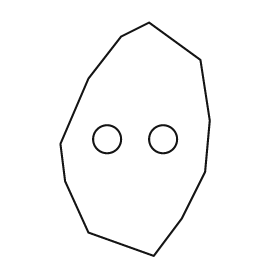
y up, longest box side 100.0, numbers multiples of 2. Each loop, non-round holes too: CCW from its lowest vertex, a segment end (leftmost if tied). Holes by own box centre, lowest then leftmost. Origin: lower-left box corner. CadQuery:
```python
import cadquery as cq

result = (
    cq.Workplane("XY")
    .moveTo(40.0, 0.0)
    .lineTo(52.0, 16.0)
    .lineTo(62.0, 36.0)
    .lineTo(64.0, 58.0)
    .lineTo(60.0, 84.0)
    .lineTo(38.0, 100.0)
    .lineTo(26.0, 94.0)
    .lineTo(12.0, 76.0)
    .lineTo(0.0, 48.0)
    .lineTo(2.0, 32.0)
    .lineTo(12.0, 10.0)
    .close()
    .moveTo(20.0, 50.0)
    .circle(6.0)
    .moveTo(44.0, 50.0)
    .circle(6.0)
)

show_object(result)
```